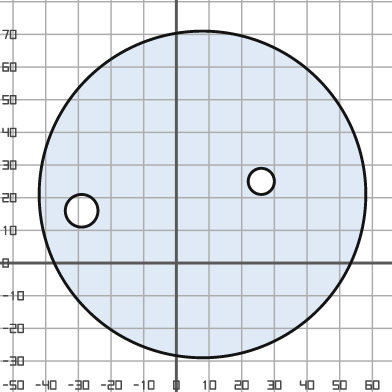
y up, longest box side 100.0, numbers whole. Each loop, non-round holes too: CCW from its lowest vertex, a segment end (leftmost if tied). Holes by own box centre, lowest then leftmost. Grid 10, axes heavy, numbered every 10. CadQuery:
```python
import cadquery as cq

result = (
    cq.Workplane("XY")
    .moveTo(8.0, 21.0)
    .circle(50.0)
    .moveTo(-29.0, 16.0)
    .circle(5.0)
    .moveTo(26.0, 25.0)
    .circle(4.0)
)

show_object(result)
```